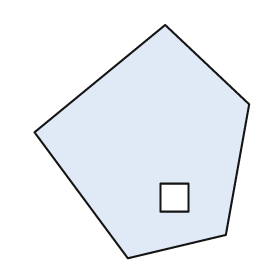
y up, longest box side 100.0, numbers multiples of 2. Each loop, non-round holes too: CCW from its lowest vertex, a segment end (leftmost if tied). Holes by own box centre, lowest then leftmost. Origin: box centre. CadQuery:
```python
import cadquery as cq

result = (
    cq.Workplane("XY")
    .moveTo(-6.0, -50.0)
    .lineTo(36.0, -40.0)
    .lineTo(46.0, 16.0)
    .lineTo(10.0, 50.0)
    .lineTo(-46.0, 4.0)
    .close()
    .moveTo(8.0, -30.0)
    .lineTo(20.0, -30.0)
    .lineTo(20.0, -18.0)
    .lineTo(8.0, -18.0)
    .close()
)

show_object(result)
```